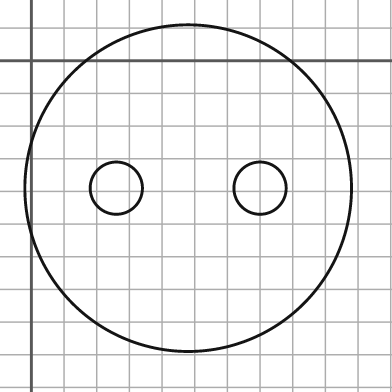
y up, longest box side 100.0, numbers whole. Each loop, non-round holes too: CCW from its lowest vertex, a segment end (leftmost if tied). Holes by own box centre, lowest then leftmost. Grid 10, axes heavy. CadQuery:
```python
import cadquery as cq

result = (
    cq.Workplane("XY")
    .moveTo(48.0, -39.0)
    .circle(50.0)
    .moveTo(26.0, -39.0)
    .circle(8.0)
    .moveTo(70.0, -39.0)
    .circle(8.0)
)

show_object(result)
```